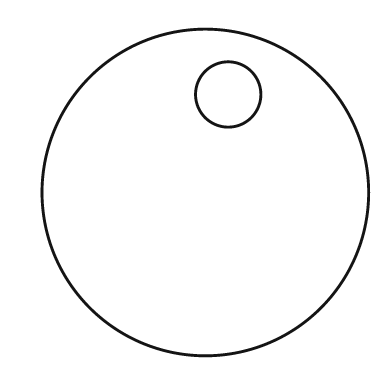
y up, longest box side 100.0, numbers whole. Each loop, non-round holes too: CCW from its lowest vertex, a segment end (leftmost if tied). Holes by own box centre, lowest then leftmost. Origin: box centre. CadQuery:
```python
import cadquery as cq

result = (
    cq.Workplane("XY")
    .moveTo(0.0, 0.0)
    .circle(50.0)
    .moveTo(7.0, 30.0)
    .circle(10.0)
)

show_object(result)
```